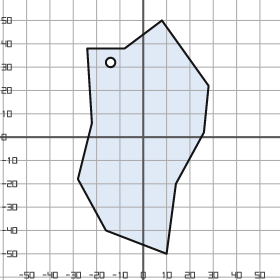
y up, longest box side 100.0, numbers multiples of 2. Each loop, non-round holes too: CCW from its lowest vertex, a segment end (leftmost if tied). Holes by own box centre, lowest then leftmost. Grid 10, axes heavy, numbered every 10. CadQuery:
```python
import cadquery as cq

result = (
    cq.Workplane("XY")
    .moveTo(10.0, -50.0)
    .lineTo(14.0, -20.0)
    .lineTo(26.0, 2.0)
    .lineTo(28.0, 22.0)
    .lineTo(8.0, 50.0)
    .lineTo(-8.0, 38.0)
    .lineTo(-24.0, 38.0)
    .lineTo(-22.0, 6.0)
    .lineTo(-28.0, -18.0)
    .lineTo(-16.0, -40.0)
    .close()
    .moveTo(-14.0, 32.0)
    .circle(2.0)
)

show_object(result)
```